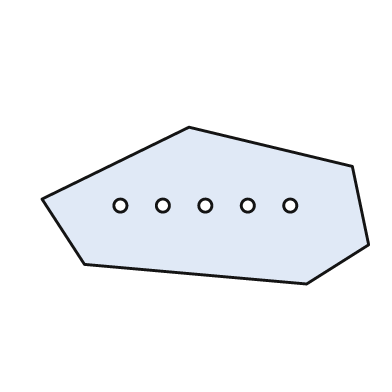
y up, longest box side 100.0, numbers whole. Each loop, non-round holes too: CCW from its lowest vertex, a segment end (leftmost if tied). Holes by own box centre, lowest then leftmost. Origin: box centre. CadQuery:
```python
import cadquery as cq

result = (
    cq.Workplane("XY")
    .moveTo(31.0, -24.0)
    .lineTo(50.0, -12.0)
    .lineTo(45.0, 12.0)
    .lineTo(-5.0, 24.0)
    .lineTo(-50.0, 2.0)
    .lineTo(-37.0, -18.0)
    .close()
    .moveTo(-26.0, 0.0)
    .circle(2.0)
    .moveTo(-13.0, 0.0)
    .circle(2.0)
    .moveTo(0.0, 0.0)
    .circle(2.0)
    .moveTo(13.0, 0.0)
    .circle(2.0)
    .moveTo(26.0, 0.0)
    .circle(2.0)
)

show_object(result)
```